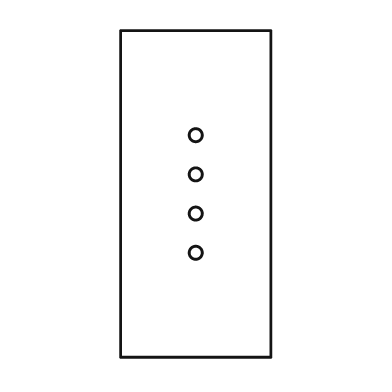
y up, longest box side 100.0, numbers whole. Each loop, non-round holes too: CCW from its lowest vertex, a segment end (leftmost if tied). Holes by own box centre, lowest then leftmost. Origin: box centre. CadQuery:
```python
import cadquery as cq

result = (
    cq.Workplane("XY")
    .moveTo(-23.0, -50.0)
    .lineTo(23.0, -50.0)
    .lineTo(23.0, 50.0)
    .lineTo(-23.0, 50.0)
    .close()
    .moveTo(0.0, -18.0)
    .circle(2.0)
    .moveTo(0.0, -6.0)
    .circle(2.0)
    .moveTo(0.0, 6.0)
    .circle(2.0)
    .moveTo(0.0, 18.0)
    .circle(2.0)
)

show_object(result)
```